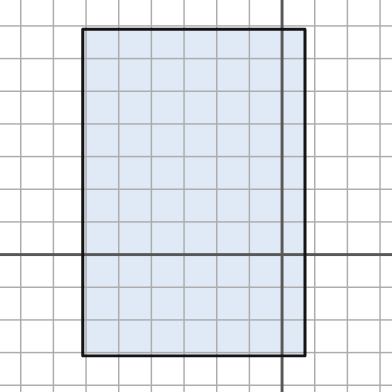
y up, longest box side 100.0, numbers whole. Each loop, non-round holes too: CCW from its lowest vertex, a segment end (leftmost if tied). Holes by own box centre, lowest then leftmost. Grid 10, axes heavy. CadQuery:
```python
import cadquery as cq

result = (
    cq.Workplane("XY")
    .moveTo(-61.0, -31.0)
    .lineTo(7.0, -31.0)
    .lineTo(7.0, 69.0)
    .lineTo(-61.0, 69.0)
    .close()
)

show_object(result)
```